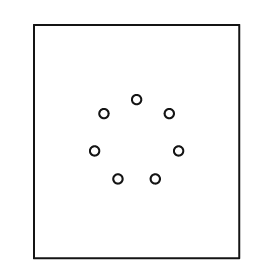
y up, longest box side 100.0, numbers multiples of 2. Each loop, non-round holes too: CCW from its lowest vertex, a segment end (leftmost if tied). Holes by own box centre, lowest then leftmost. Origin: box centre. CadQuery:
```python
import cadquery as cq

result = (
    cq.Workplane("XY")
    .moveTo(-44.0, -50.0)
    .lineTo(44.0, -50.0)
    .lineTo(44.0, 50.0)
    .lineTo(-44.0, 50.0)
    .close()
    .moveTo(-8.0, -16.0)
    .circle(2.0)
    .moveTo(8.0, -16.0)
    .circle(2.0)
    .moveTo(-18.0, -4.0)
    .circle(2.0)
    .moveTo(18.0, -4.0)
    .circle(2.0)
    .moveTo(-14.0, 12.0)
    .circle(2.0)
    .moveTo(14.0, 12.0)
    .circle(2.0)
    .moveTo(0.0, 18.0)
    .circle(2.0)
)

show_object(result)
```